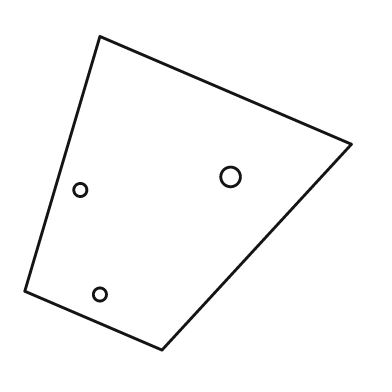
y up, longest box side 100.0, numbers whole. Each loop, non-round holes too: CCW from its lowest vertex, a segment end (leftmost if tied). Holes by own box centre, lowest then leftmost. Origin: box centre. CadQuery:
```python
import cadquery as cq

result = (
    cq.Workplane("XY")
    .moveTo(-8.0, -48.0)
    .lineTo(50.0, 15.0)
    .lineTo(-27.0, 48.0)
    .lineTo(-50.0, -30.0)
    .close()
    .moveTo(-27.0, -31.0)
    .circle(2.0)
    .moveTo(-33.0, 1.0)
    .circle(2.0)
    .moveTo(13.0, 5.0)
    .circle(3.0)
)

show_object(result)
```